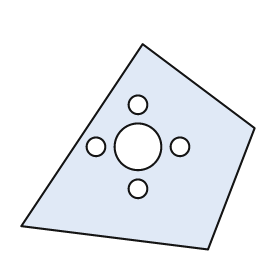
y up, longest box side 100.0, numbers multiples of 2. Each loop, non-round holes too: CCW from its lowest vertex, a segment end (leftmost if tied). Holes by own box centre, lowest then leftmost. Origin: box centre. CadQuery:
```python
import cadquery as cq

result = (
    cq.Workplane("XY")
    .moveTo(30.0, -44.0)
    .lineTo(50.0, 8.0)
    .lineTo(2.0, 44.0)
    .lineTo(-50.0, -34.0)
    .close()
    .moveTo(0.0, -18.0)
    .circle(4.0)
    .moveTo(-18.0, 0.0)
    .circle(4.0)
    .moveTo(0.0, 0.0)
    .circle(10.0)
    .moveTo(18.0, 0.0)
    .circle(4.0)
    .moveTo(0.0, 18.0)
    .circle(4.0)
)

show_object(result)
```